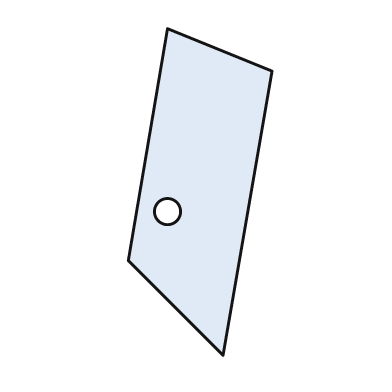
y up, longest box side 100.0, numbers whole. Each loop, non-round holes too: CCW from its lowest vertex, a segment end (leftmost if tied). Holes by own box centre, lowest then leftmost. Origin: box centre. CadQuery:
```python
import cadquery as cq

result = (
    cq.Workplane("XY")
    .moveTo(7.0, -50.0)
    .lineTo(22.0, 37.0)
    .lineTo(-10.0, 50.0)
    .lineTo(-22.0, -21.0)
    .close()
    .moveTo(-10.0, -6.0)
    .circle(4.0)
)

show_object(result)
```